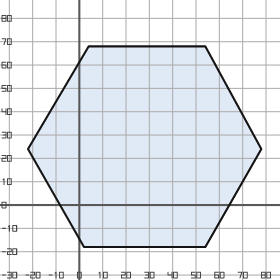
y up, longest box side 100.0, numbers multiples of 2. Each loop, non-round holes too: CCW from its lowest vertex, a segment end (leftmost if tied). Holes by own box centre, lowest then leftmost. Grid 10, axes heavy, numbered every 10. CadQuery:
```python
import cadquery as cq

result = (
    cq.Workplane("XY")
    .moveTo(2.0, -18.0)
    .lineTo(54.0, -18.0)
    .lineTo(78.0, 24.0)
    .lineTo(54.0, 68.0)
    .lineTo(4.0, 68.0)
    .lineTo(-22.0, 24.0)
    .close()
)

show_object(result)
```